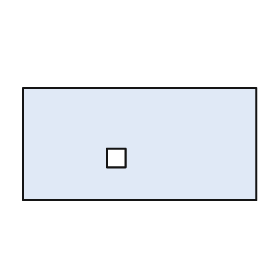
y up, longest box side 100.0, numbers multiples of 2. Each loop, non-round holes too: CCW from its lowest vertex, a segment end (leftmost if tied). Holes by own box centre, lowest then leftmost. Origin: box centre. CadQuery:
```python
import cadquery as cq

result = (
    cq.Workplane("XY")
    .moveTo(-50.0, -24.0)
    .lineTo(50.0, -24.0)
    .lineTo(50.0, 24.0)
    .lineTo(-50.0, 24.0)
    .close()
    .moveTo(-14.0, -10.0)
    .lineTo(-6.0, -10.0)
    .lineTo(-6.0, -2.0)
    .lineTo(-14.0, -2.0)
    .close()
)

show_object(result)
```